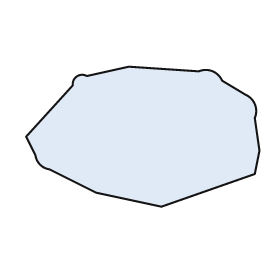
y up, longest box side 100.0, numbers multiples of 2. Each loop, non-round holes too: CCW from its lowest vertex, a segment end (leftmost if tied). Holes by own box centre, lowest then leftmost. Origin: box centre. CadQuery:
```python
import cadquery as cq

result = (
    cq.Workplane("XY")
    .moveTo(8.0, -30.0)
    .lineTo(48.0, -16.0)
    .lineTo(50.0, -6.0)
    .lineTo(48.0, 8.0)
    .threePointArc((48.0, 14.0), (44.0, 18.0))
    .lineTo(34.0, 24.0)
    .threePointArc((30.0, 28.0), (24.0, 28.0))
    .lineTo(-6.0, 30.0)
    .lineTo(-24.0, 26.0)
    .threePointArc((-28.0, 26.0), (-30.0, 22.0))
    .lineTo(-50.0, 0.0)
    .lineTo(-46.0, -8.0)
    .threePointArc((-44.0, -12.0), (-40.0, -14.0))
    .lineTo(-20.0, -24.0)
    .close()
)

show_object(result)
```